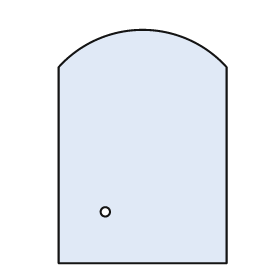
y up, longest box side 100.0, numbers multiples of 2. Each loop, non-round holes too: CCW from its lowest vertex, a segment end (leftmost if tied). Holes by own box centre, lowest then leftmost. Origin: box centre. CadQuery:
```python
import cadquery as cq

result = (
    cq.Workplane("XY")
    .moveTo(-36.0, -50.0)
    .lineTo(36.0, -50.0)
    .lineTo(36.0, 34.0)
    .threePointArc((0.0, 50.0), (-36.0, 34.0))
    .close()
    .moveTo(-16.0, -28.0)
    .circle(2.0)
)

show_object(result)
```